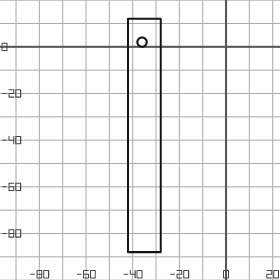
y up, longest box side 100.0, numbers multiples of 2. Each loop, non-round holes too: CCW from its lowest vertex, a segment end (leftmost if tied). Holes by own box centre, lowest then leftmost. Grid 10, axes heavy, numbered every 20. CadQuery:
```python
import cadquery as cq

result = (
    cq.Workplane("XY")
    .moveTo(-42.0, -88.0)
    .lineTo(-28.0, -88.0)
    .lineTo(-28.0, 12.0)
    .lineTo(-42.0, 12.0)
    .close()
    .moveTo(-36.0, 2.0)
    .circle(2.0)
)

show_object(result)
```